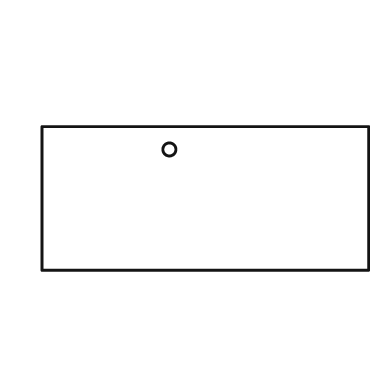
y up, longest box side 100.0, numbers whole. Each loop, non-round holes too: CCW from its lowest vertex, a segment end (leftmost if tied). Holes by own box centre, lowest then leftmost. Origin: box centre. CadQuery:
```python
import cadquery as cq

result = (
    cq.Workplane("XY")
    .moveTo(-50.0, -22.0)
    .lineTo(50.0, -22.0)
    .lineTo(50.0, 22.0)
    .lineTo(-50.0, 22.0)
    .close()
    .moveTo(-11.0, 15.0)
    .circle(2.0)
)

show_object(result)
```